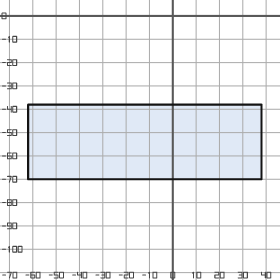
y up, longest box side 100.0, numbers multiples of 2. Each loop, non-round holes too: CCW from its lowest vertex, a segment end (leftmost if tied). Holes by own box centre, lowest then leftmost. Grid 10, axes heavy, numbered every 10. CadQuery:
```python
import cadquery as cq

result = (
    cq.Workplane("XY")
    .moveTo(-62.0, -70.0)
    .lineTo(38.0, -70.0)
    .lineTo(38.0, -38.0)
    .lineTo(-62.0, -38.0)
    .close()
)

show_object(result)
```